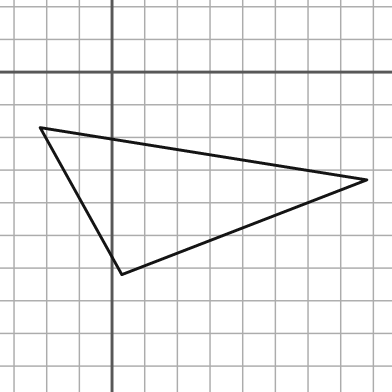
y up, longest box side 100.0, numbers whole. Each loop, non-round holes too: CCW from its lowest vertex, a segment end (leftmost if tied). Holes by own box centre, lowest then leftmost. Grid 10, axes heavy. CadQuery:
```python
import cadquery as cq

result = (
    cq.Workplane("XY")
    .moveTo(3.0, -62.0)
    .lineTo(78.0, -33.0)
    .lineTo(-22.0, -17.0)
    .close()
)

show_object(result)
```